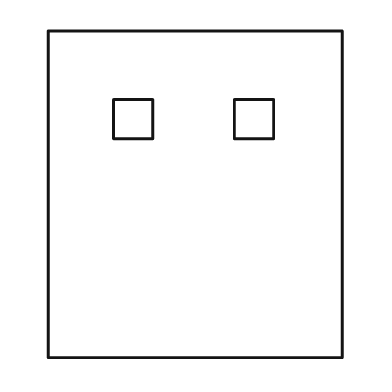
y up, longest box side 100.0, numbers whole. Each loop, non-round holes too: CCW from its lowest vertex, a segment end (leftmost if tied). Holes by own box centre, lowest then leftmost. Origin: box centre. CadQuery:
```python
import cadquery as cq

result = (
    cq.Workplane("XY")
    .moveTo(-45.0, -50.0)
    .lineTo(45.0, -50.0)
    .lineTo(45.0, 50.0)
    .lineTo(-45.0, 50.0)
    .close()
    .moveTo(-25.0, 17.0)
    .lineTo(-13.0, 17.0)
    .lineTo(-13.0, 29.0)
    .lineTo(-25.0, 29.0)
    .close()
    .moveTo(12.0, 17.0)
    .lineTo(24.0, 17.0)
    .lineTo(24.0, 29.0)
    .lineTo(12.0, 29.0)
    .close()
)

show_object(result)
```